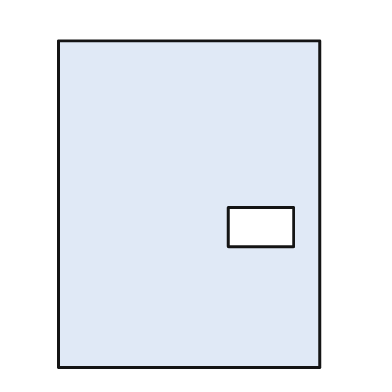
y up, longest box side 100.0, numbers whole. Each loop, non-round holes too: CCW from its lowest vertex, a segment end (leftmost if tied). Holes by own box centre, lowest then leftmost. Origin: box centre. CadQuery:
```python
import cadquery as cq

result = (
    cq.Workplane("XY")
    .moveTo(-40.0, -50.0)
    .lineTo(40.0, -50.0)
    .lineTo(40.0, 50.0)
    .lineTo(-40.0, 50.0)
    .close()
    .moveTo(12.0, -13.0)
    .lineTo(32.0, -13.0)
    .lineTo(32.0, -1.0)
    .lineTo(12.0, -1.0)
    .close()
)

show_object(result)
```